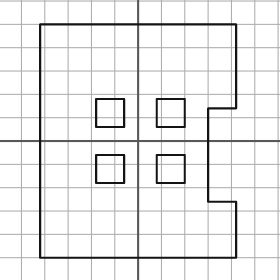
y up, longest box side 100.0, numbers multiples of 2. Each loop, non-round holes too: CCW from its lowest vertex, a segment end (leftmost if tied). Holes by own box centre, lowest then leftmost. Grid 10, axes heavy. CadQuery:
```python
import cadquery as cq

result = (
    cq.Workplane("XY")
    .moveTo(-42.0, -50.0)
    .lineTo(42.0, -50.0)
    .lineTo(42.0, -26.0)
    .lineTo(30.0, -26.0)
    .lineTo(30.0, 14.0)
    .lineTo(42.0, 14.0)
    .lineTo(42.0, 50.0)
    .lineTo(-42.0, 50.0)
    .close()
    .moveTo(-18.0, -18.0)
    .lineTo(-6.0, -18.0)
    .lineTo(-6.0, -6.0)
    .lineTo(-18.0, -6.0)
    .close()
    .moveTo(8.0, -18.0)
    .lineTo(20.0, -18.0)
    .lineTo(20.0, -6.0)
    .lineTo(8.0, -6.0)
    .close()
    .moveTo(-18.0, 6.0)
    .lineTo(-6.0, 6.0)
    .lineTo(-6.0, 18.0)
    .lineTo(-18.0, 18.0)
    .close()
    .moveTo(8.0, 6.0)
    .lineTo(20.0, 6.0)
    .lineTo(20.0, 18.0)
    .lineTo(8.0, 18.0)
    .close()
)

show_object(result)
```